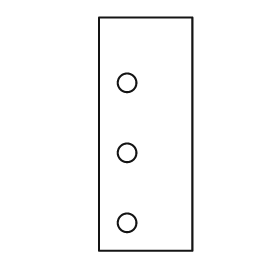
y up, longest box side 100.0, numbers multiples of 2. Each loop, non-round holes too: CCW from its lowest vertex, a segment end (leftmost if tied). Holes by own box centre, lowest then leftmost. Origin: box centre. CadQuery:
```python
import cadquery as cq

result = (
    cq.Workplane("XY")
    .moveTo(-20.0, -50.0)
    .lineTo(20.0, -50.0)
    .lineTo(20.0, 50.0)
    .lineTo(-20.0, 50.0)
    .close()
    .moveTo(-8.0, -38.0)
    .circle(4.0)
    .moveTo(-8.0, -8.0)
    .circle(4.0)
    .moveTo(-8.0, 22.0)
    .circle(4.0)
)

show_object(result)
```